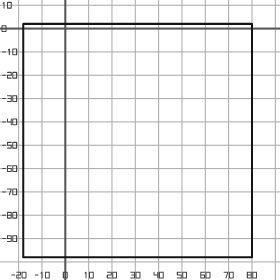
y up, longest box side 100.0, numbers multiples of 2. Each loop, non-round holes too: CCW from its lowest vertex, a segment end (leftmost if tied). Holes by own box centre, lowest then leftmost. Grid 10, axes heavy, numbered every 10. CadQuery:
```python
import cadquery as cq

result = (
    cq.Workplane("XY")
    .moveTo(-18.0, -98.0)
    .lineTo(80.0, -98.0)
    .lineTo(80.0, 2.0)
    .lineTo(-18.0, 2.0)
    .close()
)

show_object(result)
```